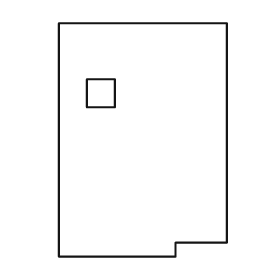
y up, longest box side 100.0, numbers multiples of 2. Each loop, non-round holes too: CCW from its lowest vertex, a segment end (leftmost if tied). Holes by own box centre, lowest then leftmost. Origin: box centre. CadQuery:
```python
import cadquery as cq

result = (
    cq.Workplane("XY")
    .moveTo(-36.0, -50.0)
    .lineTo(14.0, -50.0)
    .lineTo(14.0, -44.0)
    .lineTo(36.0, -44.0)
    .lineTo(36.0, 50.0)
    .lineTo(-36.0, 50.0)
    .close()
    .moveTo(-24.0, 14.0)
    .lineTo(-12.0, 14.0)
    .lineTo(-12.0, 26.0)
    .lineTo(-24.0, 26.0)
    .close()
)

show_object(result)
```